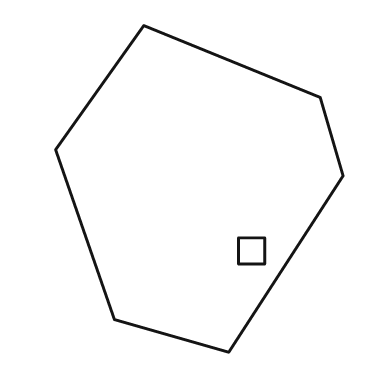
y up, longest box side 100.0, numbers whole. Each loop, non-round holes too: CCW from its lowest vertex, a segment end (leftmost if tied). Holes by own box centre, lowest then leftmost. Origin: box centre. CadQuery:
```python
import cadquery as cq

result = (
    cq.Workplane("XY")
    .moveTo(9.0, -50.0)
    .lineTo(44.0, 4.0)
    .lineTo(37.0, 28.0)
    .lineTo(-17.0, 50.0)
    .lineTo(-44.0, 12.0)
    .lineTo(-26.0, -40.0)
    .close()
    .moveTo(12.0, -23.0)
    .lineTo(20.0, -23.0)
    .lineTo(20.0, -15.0)
    .lineTo(12.0, -15.0)
    .close()
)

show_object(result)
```